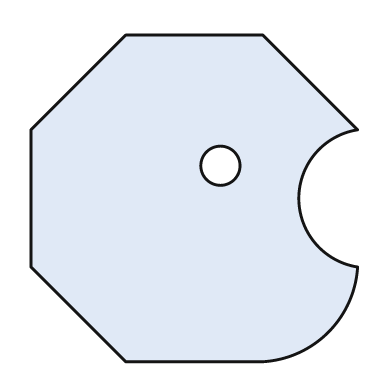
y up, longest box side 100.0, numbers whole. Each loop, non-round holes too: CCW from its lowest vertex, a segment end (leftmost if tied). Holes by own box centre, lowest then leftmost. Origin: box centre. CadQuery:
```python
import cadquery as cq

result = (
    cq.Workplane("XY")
    .moveTo(-21.0, -50.0)
    .lineTo(21.0, -50.0)
    .threePointArc((41.0, -41.0), (50.0, -21.0))
    .threePointArc((32.0, 0.0), (50.0, 21.0))
    .lineTo(21.0, 50.0)
    .lineTo(-21.0, 50.0)
    .lineTo(-50.0, 21.0)
    .lineTo(-50.0, -21.0)
    .close()
    .moveTo(8.0, 10.0)
    .circle(6.0)
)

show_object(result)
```